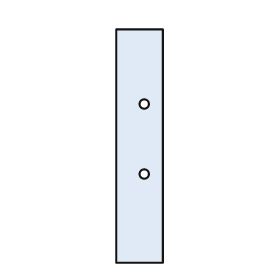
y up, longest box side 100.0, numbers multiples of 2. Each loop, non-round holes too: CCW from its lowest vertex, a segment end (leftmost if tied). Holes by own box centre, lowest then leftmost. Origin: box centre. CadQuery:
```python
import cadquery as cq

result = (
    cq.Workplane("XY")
    .moveTo(-10.0, -50.0)
    .lineTo(10.0, -50.0)
    .lineTo(10.0, 50.0)
    .lineTo(-10.0, 50.0)
    .close()
    .moveTo(2.0, -12.0)
    .circle(2.0)
    .moveTo(2.0, 18.0)
    .circle(2.0)
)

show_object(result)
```